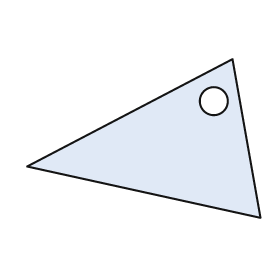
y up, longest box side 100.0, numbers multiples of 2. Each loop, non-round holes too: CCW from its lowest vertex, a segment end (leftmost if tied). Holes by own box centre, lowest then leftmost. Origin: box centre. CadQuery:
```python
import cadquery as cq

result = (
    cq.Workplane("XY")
    .moveTo(50.0, -34.0)
    .lineTo(38.0, 34.0)
    .lineTo(-50.0, -12.0)
    .close()
    .moveTo(30.0, 16.0)
    .circle(6.0)
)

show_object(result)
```